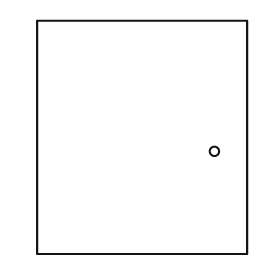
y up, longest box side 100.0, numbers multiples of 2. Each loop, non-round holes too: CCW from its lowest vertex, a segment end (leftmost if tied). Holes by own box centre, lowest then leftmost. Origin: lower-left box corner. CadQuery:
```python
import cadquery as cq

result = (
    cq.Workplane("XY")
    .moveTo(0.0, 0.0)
    .lineTo(90.0, 0.0)
    .lineTo(90.0, 100.0)
    .lineTo(0.0, 100.0)
    .close()
    .moveTo(76.0, 44.0)
    .circle(2.0)
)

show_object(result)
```